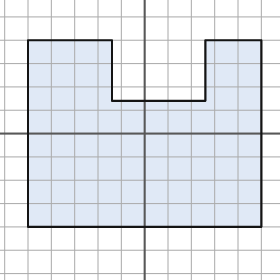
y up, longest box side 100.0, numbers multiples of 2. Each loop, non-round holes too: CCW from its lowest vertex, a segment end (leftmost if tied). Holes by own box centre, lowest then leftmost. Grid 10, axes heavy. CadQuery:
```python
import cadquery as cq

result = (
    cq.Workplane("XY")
    .moveTo(-50.0, -40.0)
    .lineTo(50.0, -40.0)
    .lineTo(50.0, 40.0)
    .lineTo(26.0, 40.0)
    .lineTo(26.0, 14.0)
    .lineTo(-14.0, 14.0)
    .lineTo(-14.0, 40.0)
    .lineTo(-50.0, 40.0)
    .close()
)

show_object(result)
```